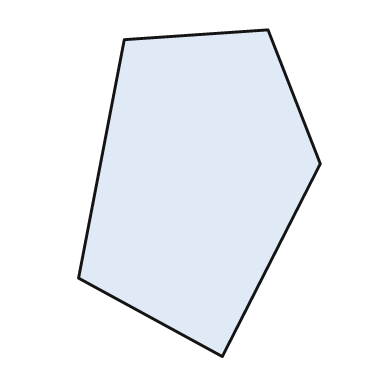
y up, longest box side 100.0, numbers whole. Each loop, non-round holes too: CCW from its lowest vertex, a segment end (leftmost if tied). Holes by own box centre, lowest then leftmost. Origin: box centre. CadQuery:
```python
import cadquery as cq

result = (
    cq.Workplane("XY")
    .moveTo(7.0, -50.0)
    .lineTo(37.0, 9.0)
    .lineTo(21.0, 50.0)
    .lineTo(-23.0, 47.0)
    .lineTo(-37.0, -26.0)
    .close()
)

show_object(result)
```